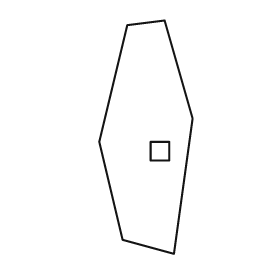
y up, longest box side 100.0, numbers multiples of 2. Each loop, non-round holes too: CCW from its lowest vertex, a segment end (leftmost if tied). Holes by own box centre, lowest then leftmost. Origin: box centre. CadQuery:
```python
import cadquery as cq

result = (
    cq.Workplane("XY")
    .moveTo(12.0, -50.0)
    .lineTo(20.0, 8.0)
    .lineTo(8.0, 50.0)
    .lineTo(-8.0, 48.0)
    .lineTo(-20.0, -2.0)
    .lineTo(-10.0, -44.0)
    .close()
    .moveTo(2.0, -10.0)
    .lineTo(10.0, -10.0)
    .lineTo(10.0, -2.0)
    .lineTo(2.0, -2.0)
    .close()
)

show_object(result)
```